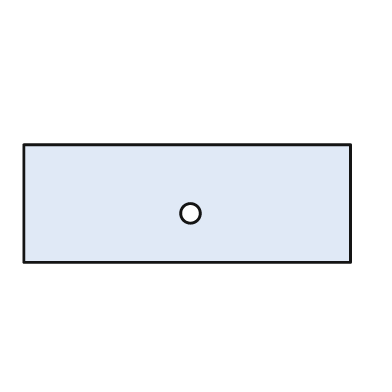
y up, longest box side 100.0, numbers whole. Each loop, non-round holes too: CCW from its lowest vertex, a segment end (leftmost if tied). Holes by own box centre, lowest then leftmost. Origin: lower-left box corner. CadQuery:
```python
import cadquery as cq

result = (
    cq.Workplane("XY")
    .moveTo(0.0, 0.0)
    .lineTo(100.0, 0.0)
    .lineTo(100.0, 36.0)
    .lineTo(0.0, 36.0)
    .close()
    .moveTo(51.0, 15.0)
    .circle(3.0)
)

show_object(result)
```